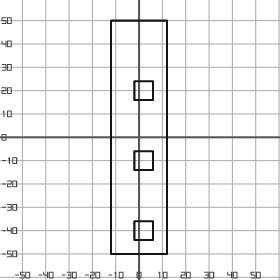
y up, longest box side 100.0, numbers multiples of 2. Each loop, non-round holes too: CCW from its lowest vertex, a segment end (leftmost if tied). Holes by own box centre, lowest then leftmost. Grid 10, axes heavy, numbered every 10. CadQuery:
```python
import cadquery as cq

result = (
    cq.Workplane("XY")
    .moveTo(-12.0, -50.0)
    .lineTo(12.0, -50.0)
    .lineTo(12.0, 50.0)
    .lineTo(-12.0, 50.0)
    .close()
    .moveTo(-2.0, -44.0)
    .lineTo(6.0, -44.0)
    .lineTo(6.0, -36.0)
    .lineTo(-2.0, -36.0)
    .close()
    .moveTo(-2.0, -14.0)
    .lineTo(6.0, -14.0)
    .lineTo(6.0, -6.0)
    .lineTo(-2.0, -6.0)
    .close()
    .moveTo(-2.0, 16.0)
    .lineTo(6.0, 16.0)
    .lineTo(6.0, 24.0)
    .lineTo(-2.0, 24.0)
    .close()
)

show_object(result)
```